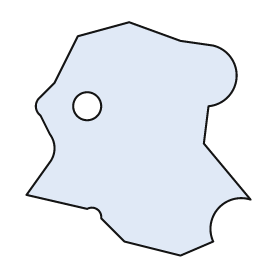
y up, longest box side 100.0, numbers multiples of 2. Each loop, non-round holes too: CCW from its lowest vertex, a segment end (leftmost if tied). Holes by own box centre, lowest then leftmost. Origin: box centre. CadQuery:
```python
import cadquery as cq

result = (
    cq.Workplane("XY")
    .moveTo(18.0, -50.0)
    .lineTo(32.0, -44.0)
    .threePointArc((34.0, -30.0), (48.0, -26.0))
    .lineTo(28.0, -2.0)
    .lineTo(30.0, 14.0)
    .threePointArc((42.0, 26.0), (32.0, 40.0))
    .lineTo(18.0, 42.0)
    .lineTo(-4.0, 50.0)
    .lineTo(-26.0, 44.0)
    .lineTo(-36.0, 24.0)
    .lineTo(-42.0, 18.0)
    .threePointArc((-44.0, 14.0), (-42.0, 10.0))
    .lineTo(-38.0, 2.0)
    .threePointArc((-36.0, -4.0), (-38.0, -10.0))
    .lineTo(-48.0, -24.0)
    .lineTo(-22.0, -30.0)
    .threePointArc((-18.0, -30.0), (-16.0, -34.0))
    .lineTo(-6.0, -44.0)
    .close()
    .moveTo(-22.0, 14.0)
    .circle(6.0)
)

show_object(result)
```